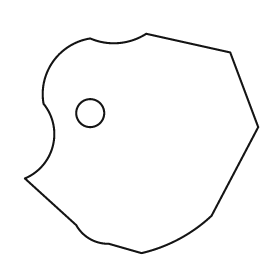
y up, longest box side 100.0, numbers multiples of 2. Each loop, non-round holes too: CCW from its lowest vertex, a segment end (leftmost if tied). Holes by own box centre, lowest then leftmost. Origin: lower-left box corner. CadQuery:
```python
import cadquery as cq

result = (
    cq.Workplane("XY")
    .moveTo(50.0, 0.0)
    .threePointArc((66.0, 6.0), (80.0, 16.0))
    .lineTo(100.0, 54.0)
    .lineTo(88.0, 86.0)
    .lineTo(52.0, 94.0)
    .threePointArc((40.0, 90.0), (28.0, 92.0))
    .threePointArc((12.0, 82.0), (8.0, 64.0))
    .threePointArc((12.0, 46.0), (0.0, 32.0))
    .lineTo(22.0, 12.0)
    .threePointArc((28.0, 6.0), (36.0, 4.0))
    .close()
    .moveTo(28.0, 60.0)
    .circle(6.0)
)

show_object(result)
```